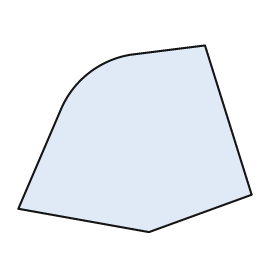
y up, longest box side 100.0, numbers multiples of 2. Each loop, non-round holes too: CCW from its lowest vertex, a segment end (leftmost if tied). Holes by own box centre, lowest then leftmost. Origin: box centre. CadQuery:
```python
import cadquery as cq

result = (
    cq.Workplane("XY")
    .moveTo(6.0, -40.0)
    .lineTo(50.0, -24.0)
    .lineTo(30.0, 40.0)
    .lineTo(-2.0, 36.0)
    .threePointArc((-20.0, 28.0), (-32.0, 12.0))
    .lineTo(-50.0, -30.0)
    .close()
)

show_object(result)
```